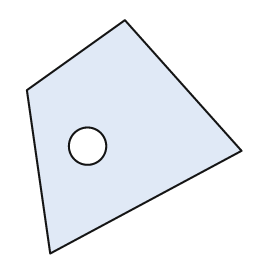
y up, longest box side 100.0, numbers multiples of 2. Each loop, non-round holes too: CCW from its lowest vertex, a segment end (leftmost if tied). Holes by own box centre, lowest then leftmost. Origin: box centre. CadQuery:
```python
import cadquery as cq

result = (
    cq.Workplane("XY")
    .moveTo(-36.0, -50.0)
    .lineTo(46.0, -6.0)
    .lineTo(-4.0, 50.0)
    .lineTo(-46.0, 20.0)
    .close()
    .moveTo(-20.0, -4.0)
    .circle(8.0)
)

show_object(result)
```